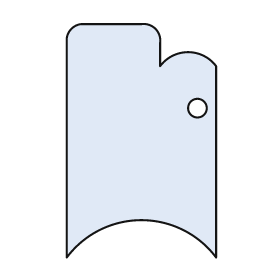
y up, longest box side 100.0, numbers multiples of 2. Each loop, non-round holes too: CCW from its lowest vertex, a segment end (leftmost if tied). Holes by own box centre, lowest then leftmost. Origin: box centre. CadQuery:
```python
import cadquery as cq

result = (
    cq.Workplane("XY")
    .moveTo(-32.0, -50.0)
    .threePointArc((0.0, -34.0), (32.0, -50.0))
    .lineTo(32.0, 32.0)
    .threePointArc((20.0, 38.0), (8.0, 32.0))
    .lineTo(8.0, 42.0)
    .threePointArc((6.0, 48.0), (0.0, 50.0))
    .lineTo(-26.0, 50.0)
    .threePointArc((-30.0, 48.0), (-32.0, 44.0))
    .close()
    .moveTo(24.0, 14.0)
    .circle(4.0)
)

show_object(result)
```